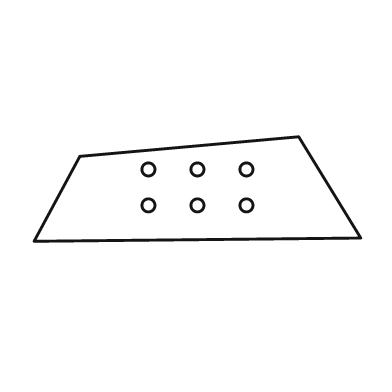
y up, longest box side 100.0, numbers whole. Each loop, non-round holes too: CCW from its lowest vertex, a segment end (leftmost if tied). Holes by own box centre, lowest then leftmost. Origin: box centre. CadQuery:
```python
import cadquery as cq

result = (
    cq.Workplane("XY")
    .moveTo(-50.0, -16.0)
    .lineTo(50.0, -15.0)
    .lineTo(31.0, 16.0)
    .lineTo(-36.0, 10.0)
    .close()
    .moveTo(-15.0, -5.0)
    .circle(2.0)
    .moveTo(0.0, -5.0)
    .circle(2.0)
    .moveTo(15.0, -5.0)
    .circle(2.0)
    .moveTo(-15.0, 6.0)
    .circle(2.0)
    .moveTo(0.0, 6.0)
    .circle(2.0)
    .moveTo(15.0, 6.0)
    .circle(2.0)
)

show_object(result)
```